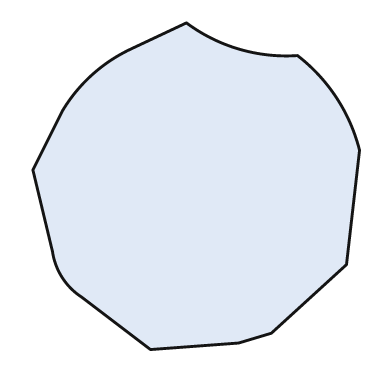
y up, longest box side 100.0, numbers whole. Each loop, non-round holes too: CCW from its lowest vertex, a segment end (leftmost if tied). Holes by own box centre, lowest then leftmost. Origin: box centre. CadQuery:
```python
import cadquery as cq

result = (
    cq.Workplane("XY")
    .moveTo(-14.0, -50.0)
    .lineTo(13.0, -48.0)
    .lineTo(23.0, -45.0)
    .lineTo(46.0, -24.0)
    .lineTo(50.0, 11.0)
    .threePointArc((43.0, 27.0), (31.0, 40.0))
    .threePointArc((13.0, 42.0), (-3.0, 50.0))
    .lineTo(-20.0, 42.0)
    .threePointArc((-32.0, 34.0), (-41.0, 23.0))
    .lineTo(-50.0, 5.0)
    .lineTo(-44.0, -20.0)
    .threePointArc((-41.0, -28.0), (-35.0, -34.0))
    .close()
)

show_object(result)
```